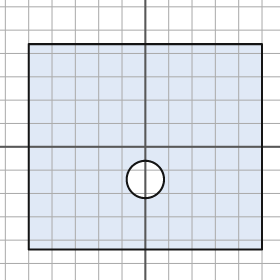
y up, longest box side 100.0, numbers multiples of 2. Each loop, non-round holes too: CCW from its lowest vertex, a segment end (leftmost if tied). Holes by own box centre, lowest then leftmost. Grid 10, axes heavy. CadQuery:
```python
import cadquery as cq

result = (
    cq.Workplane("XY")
    .moveTo(-50.0, -44.0)
    .lineTo(50.0, -44.0)
    .lineTo(50.0, 44.0)
    .lineTo(-50.0, 44.0)
    .close()
    .moveTo(0.0, -14.0)
    .circle(8.0)
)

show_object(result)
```